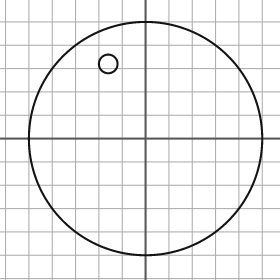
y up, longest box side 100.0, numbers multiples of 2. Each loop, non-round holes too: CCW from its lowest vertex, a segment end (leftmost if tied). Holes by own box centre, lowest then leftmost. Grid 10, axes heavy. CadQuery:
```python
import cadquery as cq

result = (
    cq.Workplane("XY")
    .moveTo(0.0, 0.0)
    .circle(50.0)
    .moveTo(-16.0, 32.0)
    .circle(4.0)
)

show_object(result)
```